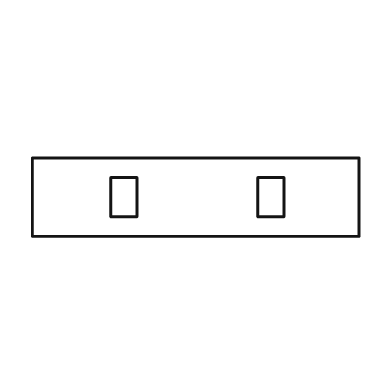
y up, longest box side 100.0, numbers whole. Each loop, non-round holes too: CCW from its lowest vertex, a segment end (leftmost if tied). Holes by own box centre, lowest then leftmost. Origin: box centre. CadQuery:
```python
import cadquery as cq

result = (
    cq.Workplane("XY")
    .moveTo(-50.0, -12.0)
    .lineTo(50.0, -12.0)
    .lineTo(50.0, 12.0)
    .lineTo(-50.0, 12.0)
    .close()
    .moveTo(-26.0, -6.0)
    .lineTo(-18.0, -6.0)
    .lineTo(-18.0, 6.0)
    .lineTo(-26.0, 6.0)
    .close()
    .moveTo(19.0, -6.0)
    .lineTo(27.0, -6.0)
    .lineTo(27.0, 6.0)
    .lineTo(19.0, 6.0)
    .close()
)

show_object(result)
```